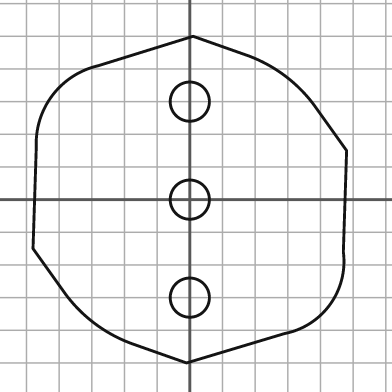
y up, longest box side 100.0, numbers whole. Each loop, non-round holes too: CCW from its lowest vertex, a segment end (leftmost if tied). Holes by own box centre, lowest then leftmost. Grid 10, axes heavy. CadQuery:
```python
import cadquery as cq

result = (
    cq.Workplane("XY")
    .moveTo(-1.0, -50.0)
    .lineTo(29.0, -41.0)
    .threePointArc((43.0, -32.0), (47.0, -16.0))
    .lineTo(48.0, 15.0)
    .lineTo(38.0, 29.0)
    .threePointArc((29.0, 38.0), (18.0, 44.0))
    .lineTo(1.0, 50.0)
    .lineTo(-28.0, 41.0)
    .threePointArc((-42.0, 32.0), (-47.0, 16.0))
    .lineTo(-48.0, -15.0)
    .lineTo(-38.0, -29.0)
    .threePointArc((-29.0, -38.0), (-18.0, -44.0))
    .close()
    .moveTo(0.0, -30.0)
    .circle(6.0)
    .moveTo(0.0, 0.0)
    .circle(6.0)
    .moveTo(0.0, 30.0)
    .circle(6.0)
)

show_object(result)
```